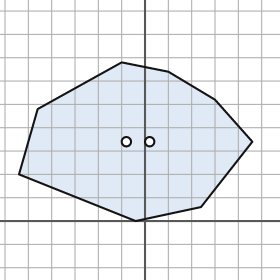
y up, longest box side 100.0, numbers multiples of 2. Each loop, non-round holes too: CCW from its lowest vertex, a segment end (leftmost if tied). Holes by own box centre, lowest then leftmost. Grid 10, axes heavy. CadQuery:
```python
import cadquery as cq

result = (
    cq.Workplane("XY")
    .moveTo(-4.0, 0.0)
    .lineTo(24.0, 6.0)
    .lineTo(46.0, 34.0)
    .lineTo(30.0, 52.0)
    .lineTo(10.0, 64.0)
    .lineTo(-10.0, 68.0)
    .lineTo(-46.0, 48.0)
    .lineTo(-54.0, 20.0)
    .close()
    .moveTo(-8.0, 34.0)
    .circle(2.0)
    .moveTo(2.0, 34.0)
    .circle(2.0)
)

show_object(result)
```